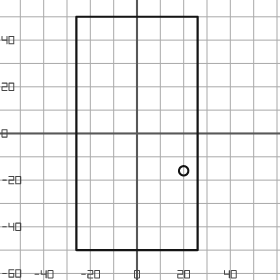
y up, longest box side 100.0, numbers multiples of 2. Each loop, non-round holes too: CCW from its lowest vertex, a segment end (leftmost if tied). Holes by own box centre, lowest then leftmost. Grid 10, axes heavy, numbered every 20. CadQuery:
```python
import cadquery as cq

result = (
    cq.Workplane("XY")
    .moveTo(-26.0, -50.0)
    .lineTo(26.0, -50.0)
    .lineTo(26.0, 50.0)
    .lineTo(-26.0, 50.0)
    .close()
    .moveTo(20.0, -16.0)
    .circle(2.0)
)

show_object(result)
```